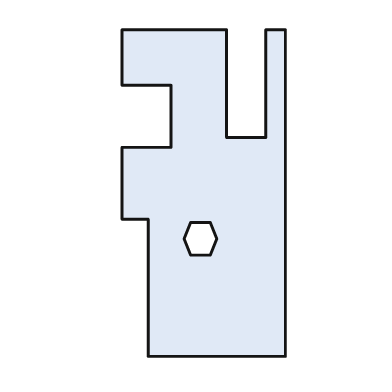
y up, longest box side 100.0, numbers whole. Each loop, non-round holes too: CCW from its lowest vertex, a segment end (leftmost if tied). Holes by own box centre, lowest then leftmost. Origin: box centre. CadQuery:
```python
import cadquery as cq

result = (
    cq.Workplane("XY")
    .moveTo(-17.0, -50.0)
    .lineTo(25.0, -50.0)
    .lineTo(25.0, 50.0)
    .lineTo(19.0, 50.0)
    .lineTo(19.0, 17.0)
    .lineTo(7.0, 17.0)
    .lineTo(7.0, 50.0)
    .lineTo(-25.0, 50.0)
    .lineTo(-25.0, 33.0)
    .lineTo(-10.0, 33.0)
    .lineTo(-10.0, 14.0)
    .lineTo(-25.0, 14.0)
    .lineTo(-25.0, -8.0)
    .lineTo(-17.0, -8.0)
    .close()
    .moveTo(-4.0, -19.0)
    .lineTo(2.0, -19.0)
    .lineTo(4.0, -14.0)
    .lineTo(2.0, -9.0)
    .lineTo(-4.0, -9.0)
    .lineTo(-6.0, -14.0)
    .close()
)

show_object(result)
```